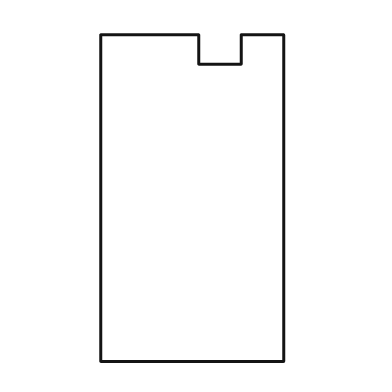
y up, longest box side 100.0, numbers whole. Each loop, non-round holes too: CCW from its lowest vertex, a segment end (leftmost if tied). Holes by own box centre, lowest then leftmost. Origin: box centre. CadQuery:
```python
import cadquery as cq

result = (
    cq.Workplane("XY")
    .moveTo(-28.0, -50.0)
    .lineTo(28.0, -50.0)
    .lineTo(28.0, 50.0)
    .lineTo(15.0, 50.0)
    .lineTo(15.0, 41.0)
    .lineTo(2.0, 41.0)
    .lineTo(2.0, 50.0)
    .lineTo(-28.0, 50.0)
    .close()
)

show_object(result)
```